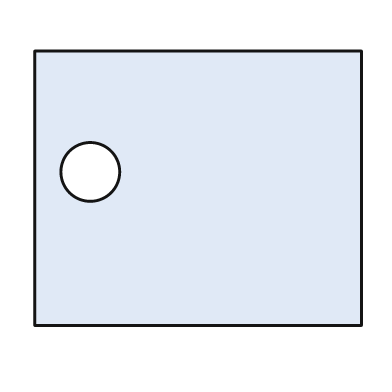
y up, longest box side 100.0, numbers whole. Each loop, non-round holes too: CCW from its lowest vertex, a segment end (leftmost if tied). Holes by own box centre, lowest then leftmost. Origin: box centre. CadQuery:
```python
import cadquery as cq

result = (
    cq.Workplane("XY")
    .moveTo(-50.0, -42.0)
    .lineTo(50.0, -42.0)
    .lineTo(50.0, 42.0)
    .lineTo(-50.0, 42.0)
    .close()
    .moveTo(-33.0, 5.0)
    .circle(9.0)
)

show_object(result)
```